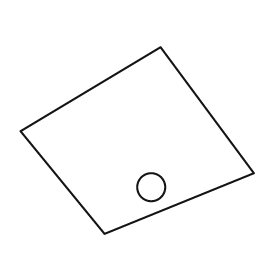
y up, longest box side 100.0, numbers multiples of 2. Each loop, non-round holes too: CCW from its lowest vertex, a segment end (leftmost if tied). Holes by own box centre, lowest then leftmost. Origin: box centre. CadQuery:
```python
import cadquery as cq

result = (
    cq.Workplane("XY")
    .moveTo(-14.0, -40.0)
    .lineTo(50.0, -14.0)
    .lineTo(10.0, 40.0)
    .lineTo(-50.0, 4.0)
    .close()
    .moveTo(6.0, -20.0)
    .circle(6.0)
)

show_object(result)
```